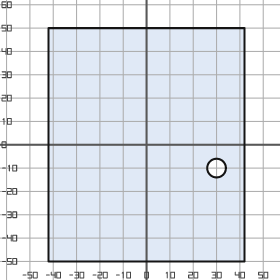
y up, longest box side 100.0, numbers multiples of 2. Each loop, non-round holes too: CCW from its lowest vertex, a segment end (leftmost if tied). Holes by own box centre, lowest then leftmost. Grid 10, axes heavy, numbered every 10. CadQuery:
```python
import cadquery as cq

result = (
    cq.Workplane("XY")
    .moveTo(-42.0, -50.0)
    .lineTo(42.0, -50.0)
    .lineTo(42.0, 50.0)
    .lineTo(-42.0, 50.0)
    .close()
    .moveTo(30.0, -10.0)
    .circle(4.0)
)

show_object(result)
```